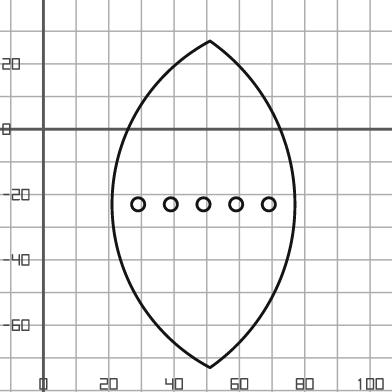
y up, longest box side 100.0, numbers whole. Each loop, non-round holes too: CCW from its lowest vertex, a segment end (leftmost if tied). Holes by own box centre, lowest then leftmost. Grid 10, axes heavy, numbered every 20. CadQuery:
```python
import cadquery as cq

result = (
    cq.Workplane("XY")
    .moveTo(51.0, -73.0)
    .threePointArc((77.0, -23.0), (51.0, 27.0))
    .threePointArc((21.0, -23.0), (51.0, -73.0))
    .close()
    .moveTo(29.0, -23.0)
    .circle(2.0)
    .moveTo(39.0, -23.0)
    .circle(2.0)
    .moveTo(49.0, -23.0)
    .circle(2.0)
    .moveTo(59.0, -23.0)
    .circle(2.0)
    .moveTo(69.0, -23.0)
    .circle(2.0)
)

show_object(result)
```